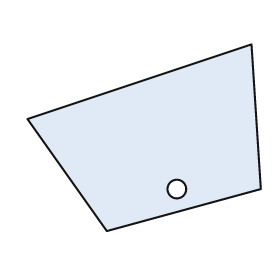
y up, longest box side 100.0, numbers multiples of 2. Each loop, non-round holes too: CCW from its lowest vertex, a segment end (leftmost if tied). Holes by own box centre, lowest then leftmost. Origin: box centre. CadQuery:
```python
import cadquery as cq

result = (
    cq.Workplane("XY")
    .moveTo(-16.0, -40.0)
    .lineTo(50.0, -22.0)
    .lineTo(46.0, 40.0)
    .lineTo(-50.0, 8.0)
    .close()
    .moveTo(14.0, -22.0)
    .circle(4.0)
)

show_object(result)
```